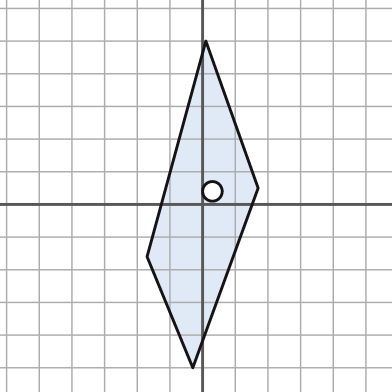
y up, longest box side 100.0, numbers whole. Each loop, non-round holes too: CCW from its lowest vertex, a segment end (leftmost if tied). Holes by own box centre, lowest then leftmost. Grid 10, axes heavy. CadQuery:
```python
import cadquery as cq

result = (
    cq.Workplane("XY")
    .moveTo(-3.0, -50.0)
    .lineTo(17.0, 5.0)
    .lineTo(1.0, 50.0)
    .lineTo(-17.0, -16.0)
    .close()
    .moveTo(3.0, 4.0)
    .circle(3.0)
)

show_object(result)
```